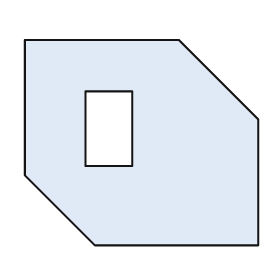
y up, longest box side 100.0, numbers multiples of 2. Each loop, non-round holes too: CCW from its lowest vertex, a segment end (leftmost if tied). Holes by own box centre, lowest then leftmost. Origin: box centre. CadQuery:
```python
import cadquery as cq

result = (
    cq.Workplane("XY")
    .moveTo(-20.0, -44.0)
    .lineTo(50.0, -44.0)
    .lineTo(50.0, 10.0)
    .lineTo(16.0, 44.0)
    .lineTo(-50.0, 44.0)
    .lineTo(-50.0, -14.0)
    .close()
    .moveTo(-24.0, -10.0)
    .lineTo(-4.0, -10.0)
    .lineTo(-4.0, 22.0)
    .lineTo(-24.0, 22.0)
    .close()
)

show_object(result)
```